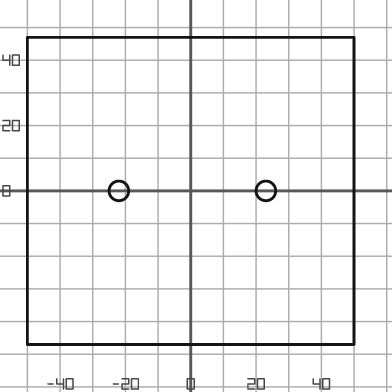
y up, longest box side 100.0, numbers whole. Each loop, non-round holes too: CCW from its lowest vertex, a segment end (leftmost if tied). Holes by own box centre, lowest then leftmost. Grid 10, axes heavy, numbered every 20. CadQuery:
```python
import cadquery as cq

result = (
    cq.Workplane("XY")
    .moveTo(-50.0, -47.0)
    .lineTo(50.0, -47.0)
    .lineTo(50.0, 47.0)
    .lineTo(-50.0, 47.0)
    .close()
    .moveTo(-22.0, 0.0)
    .circle(3.0)
    .moveTo(23.0, 0.0)
    .circle(3.0)
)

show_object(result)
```